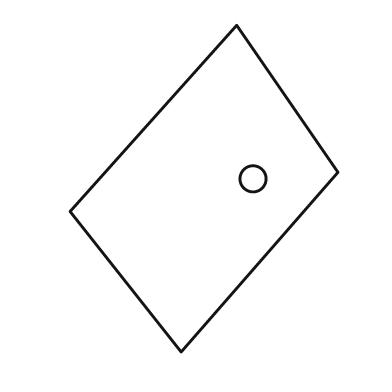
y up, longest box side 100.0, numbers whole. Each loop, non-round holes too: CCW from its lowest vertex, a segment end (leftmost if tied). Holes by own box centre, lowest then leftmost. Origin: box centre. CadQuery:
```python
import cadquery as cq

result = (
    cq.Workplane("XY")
    .moveTo(-7.0, -50.0)
    .lineTo(41.0, 5.0)
    .lineTo(10.0, 50.0)
    .lineTo(-41.0, -7.0)
    .close()
    .moveTo(15.0, 3.0)
    .circle(4.0)
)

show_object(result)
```